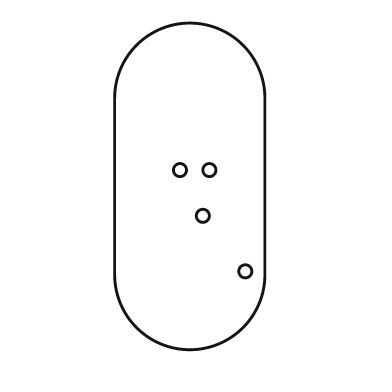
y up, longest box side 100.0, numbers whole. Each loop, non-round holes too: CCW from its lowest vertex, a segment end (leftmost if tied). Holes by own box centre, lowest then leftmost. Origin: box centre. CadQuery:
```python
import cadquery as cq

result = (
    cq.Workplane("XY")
    .moveTo(-23.0, -27.0)
    .threePointArc((0.0, -50.0), (23.0, -27.0))
    .lineTo(23.0, 27.0)
    .threePointArc((0.0, 50.0), (-23.0, 27.0))
    .close()
    .moveTo(17.0, -26.0)
    .circle(2.0)
    .moveTo(4.0, -9.0)
    .circle(2.0)
    .moveTo(-3.0, 5.0)
    .circle(2.0)
    .moveTo(6.0, 5.0)
    .circle(2.0)
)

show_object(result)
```